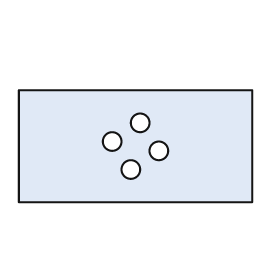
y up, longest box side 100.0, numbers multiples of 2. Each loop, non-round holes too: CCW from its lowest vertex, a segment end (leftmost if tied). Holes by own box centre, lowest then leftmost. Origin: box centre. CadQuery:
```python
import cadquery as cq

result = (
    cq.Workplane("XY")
    .moveTo(-50.0, -24.0)
    .lineTo(50.0, -24.0)
    .lineTo(50.0, 24.0)
    .lineTo(-50.0, 24.0)
    .close()
    .moveTo(-2.0, -10.0)
    .circle(4.0)
    .moveTo(10.0, -2.0)
    .circle(4.0)
    .moveTo(-10.0, 2.0)
    .circle(4.0)
    .moveTo(2.0, 10.0)
    .circle(4.0)
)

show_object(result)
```